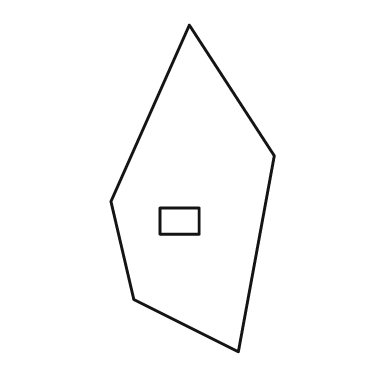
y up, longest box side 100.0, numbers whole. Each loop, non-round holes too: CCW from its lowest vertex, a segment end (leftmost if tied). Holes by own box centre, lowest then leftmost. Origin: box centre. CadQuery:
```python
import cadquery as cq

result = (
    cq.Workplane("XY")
    .moveTo(14.0, -50.0)
    .lineTo(25.0, 10.0)
    .lineTo(-1.0, 50.0)
    .lineTo(-25.0, -4.0)
    .lineTo(-18.0, -34.0)
    .close()
    .moveTo(-10.0, -14.0)
    .lineTo(2.0, -14.0)
    .lineTo(2.0, -6.0)
    .lineTo(-10.0, -6.0)
    .close()
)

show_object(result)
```